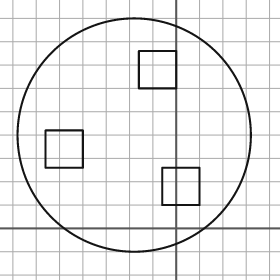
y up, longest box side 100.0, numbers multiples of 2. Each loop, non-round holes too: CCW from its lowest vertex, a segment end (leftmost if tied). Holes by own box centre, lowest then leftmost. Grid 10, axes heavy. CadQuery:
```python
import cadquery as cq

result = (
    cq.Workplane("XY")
    .moveTo(-18.0, 40.0)
    .circle(50.0)
    .moveTo(-6.0, 10.0)
    .lineTo(10.0, 10.0)
    .lineTo(10.0, 26.0)
    .lineTo(-6.0, 26.0)
    .close()
    .moveTo(-56.0, 26.0)
    .lineTo(-40.0, 26.0)
    .lineTo(-40.0, 42.0)
    .lineTo(-56.0, 42.0)
    .close()
    .moveTo(-16.0, 60.0)
    .lineTo(0.0, 60.0)
    .lineTo(0.0, 76.0)
    .lineTo(-16.0, 76.0)
    .close()
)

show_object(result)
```